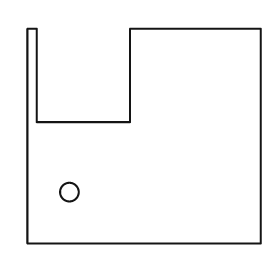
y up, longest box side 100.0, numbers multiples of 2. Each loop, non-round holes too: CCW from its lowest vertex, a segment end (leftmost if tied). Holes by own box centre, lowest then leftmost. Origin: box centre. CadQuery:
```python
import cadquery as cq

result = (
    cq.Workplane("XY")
    .moveTo(-50.0, -46.0)
    .lineTo(50.0, -46.0)
    .lineTo(50.0, 46.0)
    .lineTo(-6.0, 46.0)
    .lineTo(-6.0, 6.0)
    .lineTo(-46.0, 6.0)
    .lineTo(-46.0, 46.0)
    .lineTo(-50.0, 46.0)
    .close()
    .moveTo(-32.0, -24.0)
    .circle(4.0)
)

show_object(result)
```